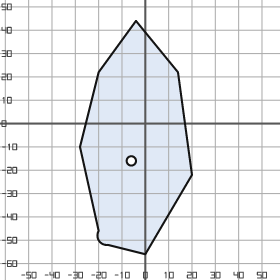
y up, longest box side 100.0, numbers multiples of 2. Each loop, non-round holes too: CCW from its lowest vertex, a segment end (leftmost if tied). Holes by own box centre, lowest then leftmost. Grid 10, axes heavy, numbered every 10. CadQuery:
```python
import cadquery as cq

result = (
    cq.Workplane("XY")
    .moveTo(0.0, -56.0)
    .lineTo(20.0, -22.0)
    .lineTo(14.0, 22.0)
    .lineTo(-4.0, 44.0)
    .lineTo(-20.0, 22.0)
    .lineTo(-28.0, -10.0)
    .lineTo(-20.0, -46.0)
    .threePointArc((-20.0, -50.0), (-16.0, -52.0))
    .close()
    .moveTo(-6.0, -16.0)
    .circle(2.0)
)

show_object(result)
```